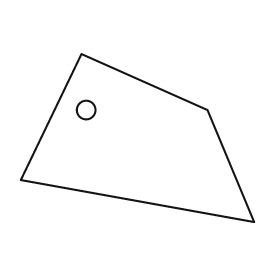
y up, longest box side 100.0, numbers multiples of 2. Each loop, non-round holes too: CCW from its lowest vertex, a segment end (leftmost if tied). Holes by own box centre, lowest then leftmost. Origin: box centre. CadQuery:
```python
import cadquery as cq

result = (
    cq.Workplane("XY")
    .moveTo(50.0, -36.0)
    .lineTo(30.0, 12.0)
    .lineTo(-24.0, 36.0)
    .lineTo(-50.0, -18.0)
    .close()
    .moveTo(-22.0, 12.0)
    .circle(4.0)
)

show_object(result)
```